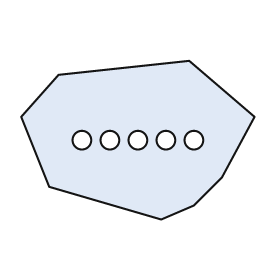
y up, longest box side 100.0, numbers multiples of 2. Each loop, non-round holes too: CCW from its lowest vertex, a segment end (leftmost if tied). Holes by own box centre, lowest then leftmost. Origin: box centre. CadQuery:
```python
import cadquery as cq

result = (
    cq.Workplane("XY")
    .moveTo(10.0, -34.0)
    .lineTo(24.0, -28.0)
    .lineTo(36.0, -16.0)
    .lineTo(50.0, 10.0)
    .lineTo(22.0, 34.0)
    .lineTo(-34.0, 28.0)
    .lineTo(-50.0, 10.0)
    .lineTo(-38.0, -20.0)
    .close()
    .moveTo(-24.0, 0.0)
    .circle(4.0)
    .moveTo(-12.0, 0.0)
    .circle(4.0)
    .moveTo(0.0, 0.0)
    .circle(4.0)
    .moveTo(12.0, 0.0)
    .circle(4.0)
    .moveTo(24.0, 0.0)
    .circle(4.0)
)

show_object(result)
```